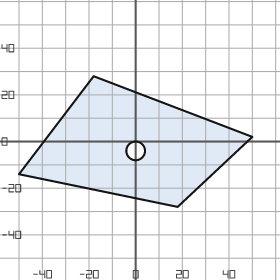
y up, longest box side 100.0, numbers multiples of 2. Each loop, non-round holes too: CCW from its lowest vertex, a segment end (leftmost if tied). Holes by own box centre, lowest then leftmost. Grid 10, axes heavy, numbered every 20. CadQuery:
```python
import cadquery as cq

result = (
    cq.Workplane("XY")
    .moveTo(18.0, -28.0)
    .lineTo(50.0, 2.0)
    .lineTo(-18.0, 28.0)
    .lineTo(-50.0, -14.0)
    .close()
    .moveTo(0.0, -4.0)
    .circle(4.0)
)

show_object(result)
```